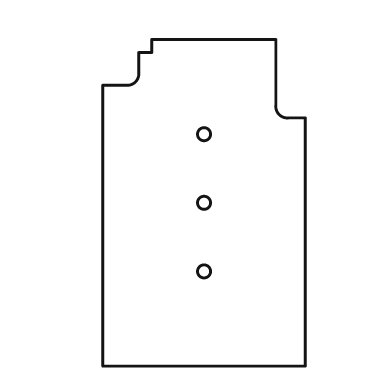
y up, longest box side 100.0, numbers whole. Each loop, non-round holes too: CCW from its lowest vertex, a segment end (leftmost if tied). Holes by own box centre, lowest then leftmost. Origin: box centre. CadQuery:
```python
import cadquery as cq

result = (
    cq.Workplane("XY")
    .moveTo(-31.0, -50.0)
    .lineTo(31.0, -50.0)
    .lineTo(31.0, 26.0)
    .lineTo(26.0, 26.0)
    .threePointArc((23.0, 27.0), (22.0, 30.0))
    .lineTo(22.0, 50.0)
    .lineTo(-16.0, 50.0)
    .lineTo(-16.0, 46.0)
    .lineTo(-20.0, 46.0)
    .lineTo(-20.0, 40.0)
    .threePointArc((-21.0, 37.0), (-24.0, 36.0))
    .lineTo(-31.0, 36.0)
    .close()
    .moveTo(0.0, -21.0)
    .circle(2.0)
    .moveTo(0.0, 0.0)
    .circle(2.0)
    .moveTo(0.0, 21.0)
    .circle(2.0)
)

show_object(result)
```